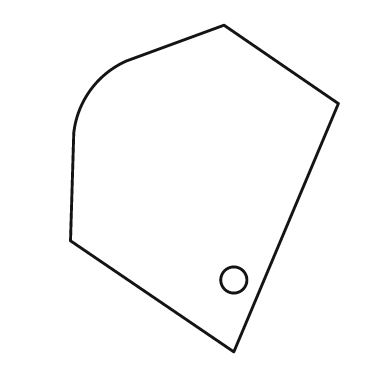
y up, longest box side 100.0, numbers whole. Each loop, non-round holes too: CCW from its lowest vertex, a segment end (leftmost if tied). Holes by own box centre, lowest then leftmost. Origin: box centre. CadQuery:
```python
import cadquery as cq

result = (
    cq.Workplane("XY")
    .moveTo(9.0, -50.0)
    .lineTo(41.0, 26.0)
    .lineTo(6.0, 50.0)
    .lineTo(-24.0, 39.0)
    .threePointArc((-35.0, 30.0), (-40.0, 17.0))
    .lineTo(-41.0, -16.0)
    .close()
    .moveTo(9.0, -28.0)
    .circle(4.0)
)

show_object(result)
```